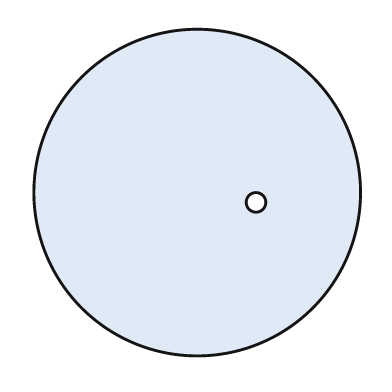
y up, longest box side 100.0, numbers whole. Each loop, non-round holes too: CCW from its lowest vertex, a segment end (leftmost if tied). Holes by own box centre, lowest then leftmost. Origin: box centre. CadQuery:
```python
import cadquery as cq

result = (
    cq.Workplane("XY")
    .moveTo(0.0, 0.0)
    .circle(50.0)
    .moveTo(18.0, -3.0)
    .circle(3.0)
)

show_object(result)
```